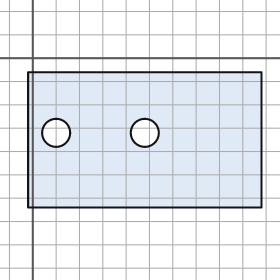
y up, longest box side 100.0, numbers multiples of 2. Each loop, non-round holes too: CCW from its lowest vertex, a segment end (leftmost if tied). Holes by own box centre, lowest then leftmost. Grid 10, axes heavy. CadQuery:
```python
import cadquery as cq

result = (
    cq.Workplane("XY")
    .moveTo(-2.0, -64.0)
    .lineTo(98.0, -64.0)
    .lineTo(98.0, -6.0)
    .lineTo(-2.0, -6.0)
    .close()
    .moveTo(10.0, -32.0)
    .circle(6.0)
    .moveTo(48.0, -32.0)
    .circle(6.0)
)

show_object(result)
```